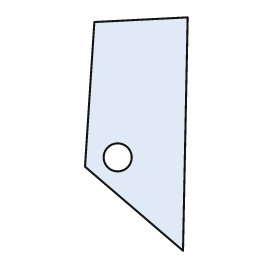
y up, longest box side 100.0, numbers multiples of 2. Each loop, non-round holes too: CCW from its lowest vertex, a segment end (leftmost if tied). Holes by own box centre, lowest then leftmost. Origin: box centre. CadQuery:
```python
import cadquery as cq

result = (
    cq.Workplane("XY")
    .moveTo(20.0, -50.0)
    .lineTo(22.0, 50.0)
    .lineTo(-18.0, 48.0)
    .lineTo(-22.0, -14.0)
    .close()
    .moveTo(-8.0, -10.0)
    .circle(6.0)
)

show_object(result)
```